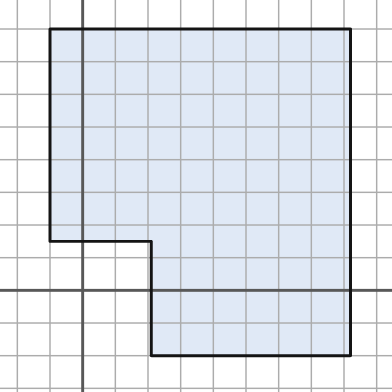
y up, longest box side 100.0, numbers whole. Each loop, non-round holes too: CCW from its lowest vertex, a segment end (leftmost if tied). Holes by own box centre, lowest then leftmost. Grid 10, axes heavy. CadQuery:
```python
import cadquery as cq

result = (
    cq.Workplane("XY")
    .moveTo(21.0, -20.0)
    .lineTo(82.0, -20.0)
    .lineTo(82.0, 80.0)
    .lineTo(-10.0, 80.0)
    .lineTo(-10.0, 15.0)
    .lineTo(21.0, 15.0)
    .close()
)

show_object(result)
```